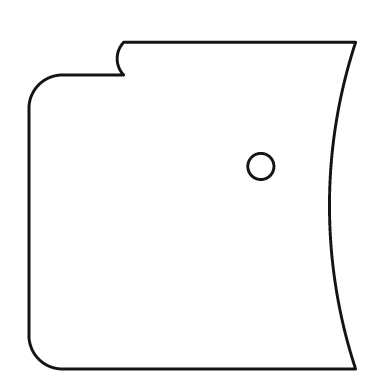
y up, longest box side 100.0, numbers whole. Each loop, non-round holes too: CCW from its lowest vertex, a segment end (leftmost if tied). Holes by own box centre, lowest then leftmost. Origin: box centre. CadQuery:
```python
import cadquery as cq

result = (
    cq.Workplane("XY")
    .moveTo(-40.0, -50.0)
    .lineTo(50.0, -50.0)
    .threePointArc((42.0, 0.0), (50.0, 50.0))
    .lineTo(-21.0, 50.0)
    .threePointArc((-23.0, 45.0), (-21.0, 40.0))
    .lineTo(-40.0, 40.0)
    .threePointArc((-47.0, 37.0), (-50.0, 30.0))
    .lineTo(-50.0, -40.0)
    .threePointArc((-47.0, -47.0), (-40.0, -50.0))
    .close()
    .moveTo(21.0, 12.0)
    .circle(4.0)
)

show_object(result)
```